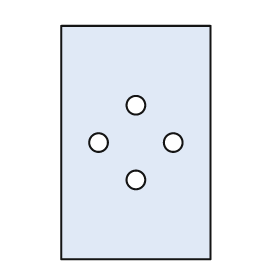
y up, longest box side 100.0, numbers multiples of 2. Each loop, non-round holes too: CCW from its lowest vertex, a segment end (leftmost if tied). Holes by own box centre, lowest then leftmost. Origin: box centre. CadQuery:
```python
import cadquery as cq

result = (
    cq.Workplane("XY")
    .moveTo(-32.0, -50.0)
    .lineTo(32.0, -50.0)
    .lineTo(32.0, 50.0)
    .lineTo(-32.0, 50.0)
    .close()
    .moveTo(0.0, -16.0)
    .circle(4.0)
    .moveTo(-16.0, 0.0)
    .circle(4.0)
    .moveTo(16.0, 0.0)
    .circle(4.0)
    .moveTo(0.0, 16.0)
    .circle(4.0)
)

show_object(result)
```